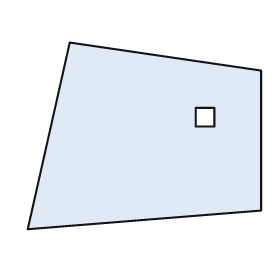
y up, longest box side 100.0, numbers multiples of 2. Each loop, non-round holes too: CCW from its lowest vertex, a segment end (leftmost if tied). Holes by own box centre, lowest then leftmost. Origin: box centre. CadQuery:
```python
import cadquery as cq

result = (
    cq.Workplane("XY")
    .moveTo(-50.0, -40.0)
    .lineTo(50.0, -32.0)
    .lineTo(50.0, 28.0)
    .lineTo(-32.0, 40.0)
    .close()
    .moveTo(22.0, 4.0)
    .lineTo(30.0, 4.0)
    .lineTo(30.0, 12.0)
    .lineTo(22.0, 12.0)
    .close()
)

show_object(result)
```